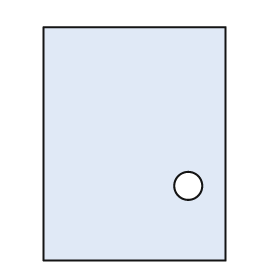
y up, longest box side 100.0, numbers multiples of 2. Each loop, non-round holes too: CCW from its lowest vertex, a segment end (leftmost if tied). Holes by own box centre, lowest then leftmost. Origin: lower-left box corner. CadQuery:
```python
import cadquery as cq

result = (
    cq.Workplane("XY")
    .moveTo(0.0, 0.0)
    .lineTo(78.0, 0.0)
    .lineTo(78.0, 100.0)
    .lineTo(0.0, 100.0)
    .close()
    .moveTo(62.0, 32.0)
    .circle(6.0)
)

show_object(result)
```